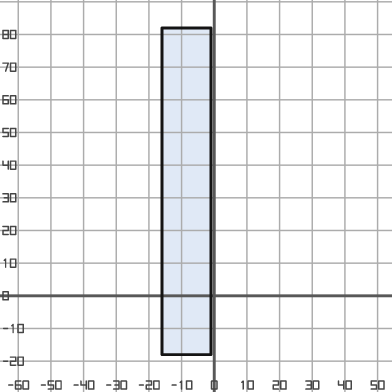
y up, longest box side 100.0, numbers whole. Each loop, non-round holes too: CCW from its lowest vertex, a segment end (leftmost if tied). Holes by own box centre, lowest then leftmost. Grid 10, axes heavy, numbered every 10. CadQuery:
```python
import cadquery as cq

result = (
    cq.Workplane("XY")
    .moveTo(-16.0, -18.0)
    .lineTo(-1.0, -18.0)
    .lineTo(-1.0, 82.0)
    .lineTo(-16.0, 82.0)
    .close()
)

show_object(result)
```